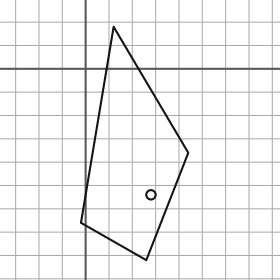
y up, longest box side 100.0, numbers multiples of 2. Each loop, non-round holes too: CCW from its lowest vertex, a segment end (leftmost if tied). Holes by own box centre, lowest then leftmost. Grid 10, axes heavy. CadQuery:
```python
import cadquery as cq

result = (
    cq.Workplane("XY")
    .moveTo(26.0, -82.0)
    .lineTo(44.0, -36.0)
    .lineTo(12.0, 18.0)
    .lineTo(-2.0, -66.0)
    .close()
    .moveTo(28.0, -54.0)
    .circle(2.0)
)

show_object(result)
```